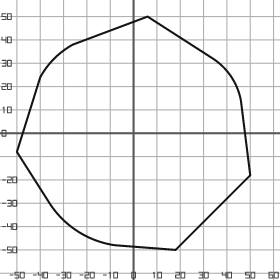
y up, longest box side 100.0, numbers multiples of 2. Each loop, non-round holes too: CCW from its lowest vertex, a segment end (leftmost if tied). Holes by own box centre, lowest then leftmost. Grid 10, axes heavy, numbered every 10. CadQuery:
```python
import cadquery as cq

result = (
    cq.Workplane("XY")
    .moveTo(18.0, -50.0)
    .lineTo(50.0, -18.0)
    .lineTo(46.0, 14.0)
    .threePointArc((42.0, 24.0), (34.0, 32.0))
    .lineTo(6.0, 50.0)
    .lineTo(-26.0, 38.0)
    .threePointArc((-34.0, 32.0), (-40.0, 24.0))
    .lineTo(-50.0, -8.0)
    .lineTo(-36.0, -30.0)
    .threePointArc((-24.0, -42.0), (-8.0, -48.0))
    .close()
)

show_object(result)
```